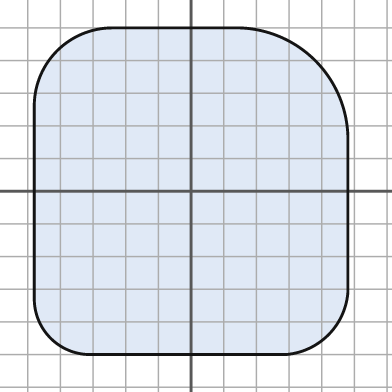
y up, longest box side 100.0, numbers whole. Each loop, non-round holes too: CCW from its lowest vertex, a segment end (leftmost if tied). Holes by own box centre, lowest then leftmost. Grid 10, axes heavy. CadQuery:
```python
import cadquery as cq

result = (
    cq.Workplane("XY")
    .moveTo(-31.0, -50.0)
    .lineTo(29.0, -50.0)
    .threePointArc((42.0, -44.0), (48.0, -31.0))
    .lineTo(48.0, 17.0)
    .threePointArc((38.0, 40.0), (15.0, 50.0))
    .lineTo(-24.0, 50.0)
    .threePointArc((-41.0, 43.0), (-48.0, 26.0))
    .lineTo(-48.0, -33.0)
    .threePointArc((-43.0, -45.0), (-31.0, -50.0))
    .close()
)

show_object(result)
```